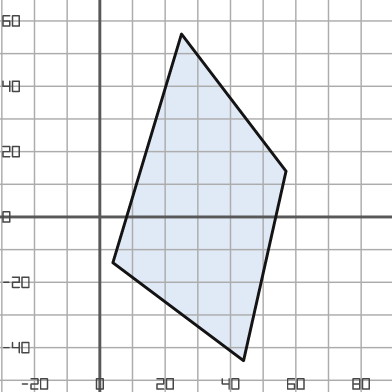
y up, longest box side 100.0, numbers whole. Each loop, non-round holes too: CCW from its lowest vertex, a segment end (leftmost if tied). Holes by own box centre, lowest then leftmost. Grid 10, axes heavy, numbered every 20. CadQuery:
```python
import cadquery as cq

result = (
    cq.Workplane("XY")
    .moveTo(44.0, -44.0)
    .lineTo(57.0, 14.0)
    .lineTo(25.0, 56.0)
    .lineTo(4.0, -14.0)
    .close()
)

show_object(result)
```